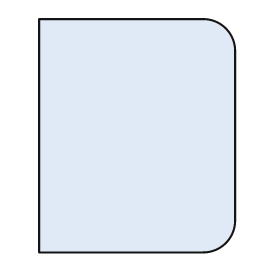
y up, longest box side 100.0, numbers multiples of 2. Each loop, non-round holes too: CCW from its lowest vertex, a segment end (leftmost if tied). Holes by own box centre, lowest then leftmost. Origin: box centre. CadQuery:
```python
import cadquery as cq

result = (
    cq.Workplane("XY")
    .moveTo(-42.0, -50.0)
    .lineTo(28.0, -50.0)
    .threePointArc((38.0, -46.0), (42.0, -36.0))
    .lineTo(42.0, 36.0)
    .threePointArc((38.0, 46.0), (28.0, 50.0))
    .lineTo(-42.0, 50.0)
    .close()
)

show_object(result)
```